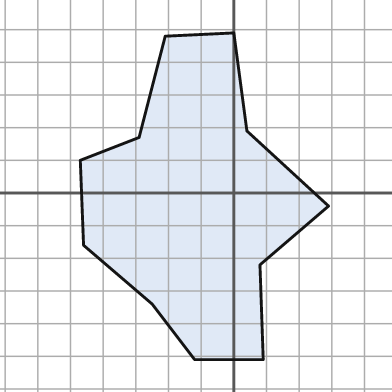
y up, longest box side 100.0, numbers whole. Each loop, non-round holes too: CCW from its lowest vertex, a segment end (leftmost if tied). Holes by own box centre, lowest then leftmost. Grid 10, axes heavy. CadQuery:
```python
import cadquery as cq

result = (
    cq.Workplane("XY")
    .moveTo(-12.0, -51.0)
    .lineTo(9.0, -51.0)
    .lineTo(8.0, -22.0)
    .lineTo(29.0, -4.0)
    .lineTo(4.0, 19.0)
    .lineTo(0.0, 49.0)
    .lineTo(-21.0, 48.0)
    .lineTo(-29.0, 17.0)
    .lineTo(-47.0, 10.0)
    .lineTo(-46.0, -16.0)
    .lineTo(-25.0, -34.0)
    .close()
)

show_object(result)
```